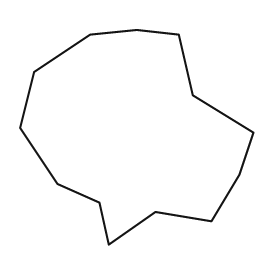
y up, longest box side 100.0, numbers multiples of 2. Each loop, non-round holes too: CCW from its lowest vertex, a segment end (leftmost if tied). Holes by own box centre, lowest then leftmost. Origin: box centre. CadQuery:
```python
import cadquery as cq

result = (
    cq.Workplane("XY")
    .moveTo(-12.0, -46.0)
    .lineTo(8.0, -32.0)
    .lineTo(32.0, -36.0)
    .lineTo(44.0, -16.0)
    .lineTo(50.0, 2.0)
    .lineTo(24.0, 18.0)
    .lineTo(18.0, 44.0)
    .lineTo(0.0, 46.0)
    .lineTo(-20.0, 44.0)
    .lineTo(-44.0, 28.0)
    .lineTo(-50.0, 4.0)
    .lineTo(-34.0, -20.0)
    .lineTo(-16.0, -28.0)
    .close()
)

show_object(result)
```